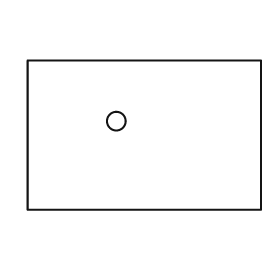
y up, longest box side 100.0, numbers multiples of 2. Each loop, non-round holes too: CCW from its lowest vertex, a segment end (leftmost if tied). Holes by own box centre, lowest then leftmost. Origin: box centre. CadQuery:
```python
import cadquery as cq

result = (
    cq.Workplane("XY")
    .moveTo(-50.0, -32.0)
    .lineTo(50.0, -32.0)
    .lineTo(50.0, 32.0)
    .lineTo(-50.0, 32.0)
    .close()
    .moveTo(-12.0, 6.0)
    .circle(4.0)
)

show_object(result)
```